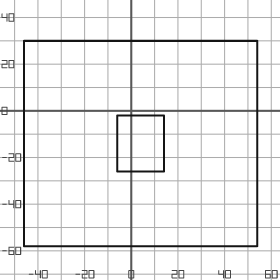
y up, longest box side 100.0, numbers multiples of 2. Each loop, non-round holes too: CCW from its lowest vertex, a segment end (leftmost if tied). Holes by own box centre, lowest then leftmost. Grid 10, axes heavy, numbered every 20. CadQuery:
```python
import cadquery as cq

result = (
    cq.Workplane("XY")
    .moveTo(-46.0, -58.0)
    .lineTo(54.0, -58.0)
    .lineTo(54.0, 30.0)
    .lineTo(-46.0, 30.0)
    .close()
    .moveTo(-6.0, -26.0)
    .lineTo(14.0, -26.0)
    .lineTo(14.0, -2.0)
    .lineTo(-6.0, -2.0)
    .close()
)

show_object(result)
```